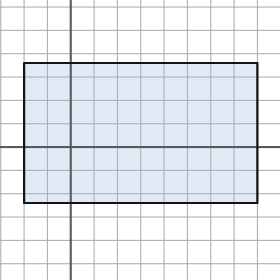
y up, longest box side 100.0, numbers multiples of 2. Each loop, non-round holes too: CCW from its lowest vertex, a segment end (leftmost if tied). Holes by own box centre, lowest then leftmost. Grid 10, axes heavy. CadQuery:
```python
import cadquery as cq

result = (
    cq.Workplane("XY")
    .moveTo(-20.0, -24.0)
    .lineTo(80.0, -24.0)
    .lineTo(80.0, 36.0)
    .lineTo(-20.0, 36.0)
    .close()
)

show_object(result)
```